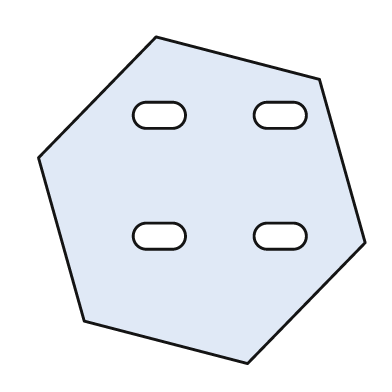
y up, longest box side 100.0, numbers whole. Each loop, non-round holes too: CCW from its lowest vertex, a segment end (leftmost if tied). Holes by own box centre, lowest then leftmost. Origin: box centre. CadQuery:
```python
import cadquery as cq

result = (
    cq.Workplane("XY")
    .moveTo(14.0, -50.0)
    .lineTo(50.0, -13.0)
    .lineTo(36.0, 37.0)
    .lineTo(-14.0, 50.0)
    .lineTo(-50.0, 13.0)
    .lineTo(-36.0, -37.0)
    .close()
    .moveTo(-17.0, -15.0)
    .lineTo(-9.0, -15.0)
    .threePointArc((-5.0, -11.0), (-9.0, -7.0))
    .lineTo(-17.0, -7.0)
    .threePointArc((-21.0, -11.0), (-17.0, -15.0))
    .close()
    .moveTo(20.0, -15.0)
    .lineTo(28.0, -15.0)
    .threePointArc((32.0, -11.0), (28.0, -7.0))
    .lineTo(20.0, -7.0)
    .threePointArc((16.0, -11.0), (20.0, -15.0))
    .close()
    .moveTo(-17.0, 22.0)
    .lineTo(-9.0, 22.0)
    .threePointArc((-5.0, 26.0), (-9.0, 30.0))
    .lineTo(-17.0, 30.0)
    .threePointArc((-21.0, 26.0), (-17.0, 22.0))
    .close()
    .moveTo(20.0, 22.0)
    .lineTo(28.0, 22.0)
    .threePointArc((32.0, 26.0), (28.0, 30.0))
    .lineTo(20.0, 30.0)
    .threePointArc((16.0, 26.0), (20.0, 22.0))
    .close()
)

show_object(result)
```